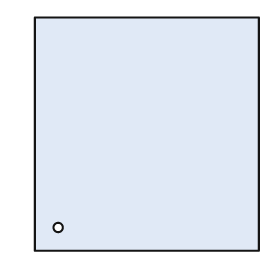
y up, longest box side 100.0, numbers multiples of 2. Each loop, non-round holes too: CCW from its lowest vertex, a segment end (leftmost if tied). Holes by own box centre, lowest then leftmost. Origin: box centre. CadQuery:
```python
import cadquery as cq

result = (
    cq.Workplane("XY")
    .moveTo(-48.0, -50.0)
    .lineTo(48.0, -50.0)
    .lineTo(48.0, 50.0)
    .lineTo(-48.0, 50.0)
    .close()
    .moveTo(-38.0, -40.0)
    .circle(2.0)
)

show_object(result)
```